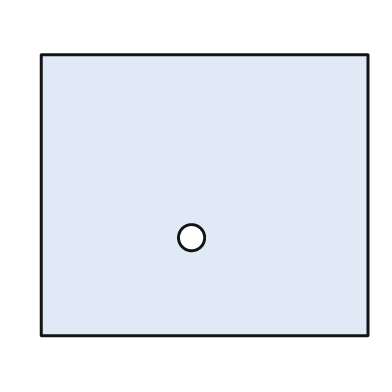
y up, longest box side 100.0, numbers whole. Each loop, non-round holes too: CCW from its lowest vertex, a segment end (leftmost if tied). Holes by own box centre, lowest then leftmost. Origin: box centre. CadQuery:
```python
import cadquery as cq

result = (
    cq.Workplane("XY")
    .moveTo(-50.0, -43.0)
    .lineTo(50.0, -43.0)
    .lineTo(50.0, 43.0)
    .lineTo(-50.0, 43.0)
    .close()
    .moveTo(-4.0, -13.0)
    .circle(4.0)
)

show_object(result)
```